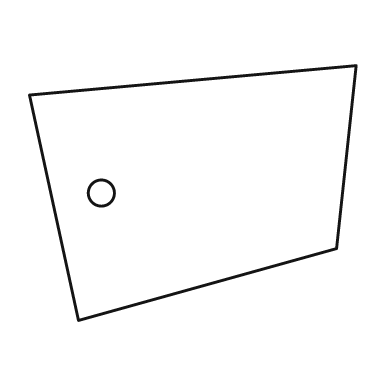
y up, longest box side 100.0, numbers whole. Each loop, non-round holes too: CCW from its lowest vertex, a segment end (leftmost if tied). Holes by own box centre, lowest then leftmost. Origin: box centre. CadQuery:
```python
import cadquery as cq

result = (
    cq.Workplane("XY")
    .moveTo(-35.0, -39.0)
    .lineTo(44.0, -17.0)
    .lineTo(50.0, 39.0)
    .lineTo(-50.0, 30.0)
    .close()
    .moveTo(-28.0, 0.0)
    .circle(4.0)
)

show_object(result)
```